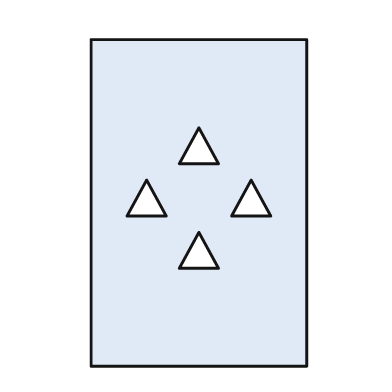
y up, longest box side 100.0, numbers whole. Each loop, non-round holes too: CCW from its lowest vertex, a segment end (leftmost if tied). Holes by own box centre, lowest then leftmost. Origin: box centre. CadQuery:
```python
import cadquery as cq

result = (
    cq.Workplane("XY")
    .moveTo(-33.0, -50.0)
    .lineTo(33.0, -50.0)
    .lineTo(33.0, 50.0)
    .lineTo(-33.0, 50.0)
    .close()
    .moveTo(-6.0, -20.0)
    .lineTo(6.0, -20.0)
    .lineTo(0.0, -9.0)
    .close()
    .moveTo(-22.0, -4.0)
    .lineTo(-10.0, -4.0)
    .lineTo(-16.0, 7.0)
    .close()
    .moveTo(10.0, -4.0)
    .lineTo(22.0, -4.0)
    .lineTo(16.0, 7.0)
    .close()
    .moveTo(-6.0, 12.0)
    .lineTo(6.0, 12.0)
    .lineTo(0.0, 23.0)
    .close()
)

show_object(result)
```